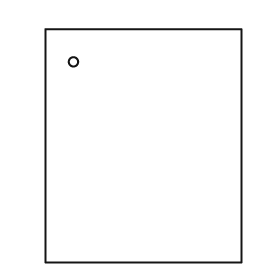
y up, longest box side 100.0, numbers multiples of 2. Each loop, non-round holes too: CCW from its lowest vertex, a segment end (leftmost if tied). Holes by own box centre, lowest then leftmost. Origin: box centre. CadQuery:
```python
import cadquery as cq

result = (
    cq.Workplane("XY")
    .moveTo(-42.0, -50.0)
    .lineTo(42.0, -50.0)
    .lineTo(42.0, 50.0)
    .lineTo(-42.0, 50.0)
    .close()
    .moveTo(-30.0, 36.0)
    .circle(2.0)
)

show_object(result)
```